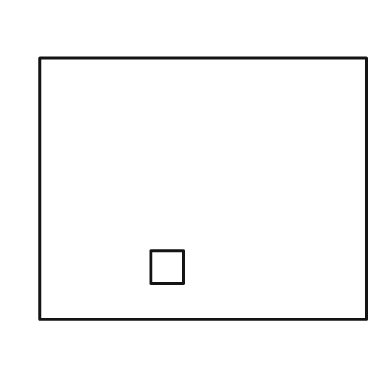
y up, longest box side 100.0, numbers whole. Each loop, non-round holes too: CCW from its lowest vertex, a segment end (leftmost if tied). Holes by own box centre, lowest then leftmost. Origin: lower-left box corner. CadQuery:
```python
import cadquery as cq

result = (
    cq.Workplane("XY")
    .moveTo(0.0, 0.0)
    .lineTo(100.0, 0.0)
    .lineTo(100.0, 80.0)
    .lineTo(0.0, 80.0)
    .close()
    .moveTo(34.0, 11.0)
    .lineTo(44.0, 11.0)
    .lineTo(44.0, 21.0)
    .lineTo(34.0, 21.0)
    .close()
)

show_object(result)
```